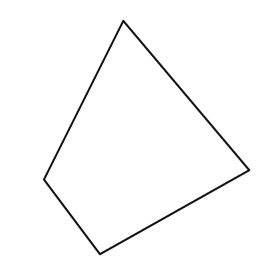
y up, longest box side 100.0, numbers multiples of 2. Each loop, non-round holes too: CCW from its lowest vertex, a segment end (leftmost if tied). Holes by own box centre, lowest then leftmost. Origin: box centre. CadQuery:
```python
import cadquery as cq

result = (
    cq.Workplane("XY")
    .moveTo(-20.0, -50.0)
    .lineTo(44.0, -14.0)
    .lineTo(-10.0, 50.0)
    .lineTo(-44.0, -18.0)
    .close()
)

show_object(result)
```